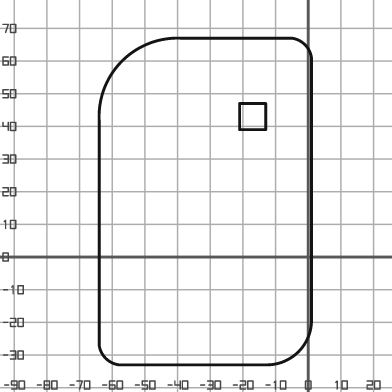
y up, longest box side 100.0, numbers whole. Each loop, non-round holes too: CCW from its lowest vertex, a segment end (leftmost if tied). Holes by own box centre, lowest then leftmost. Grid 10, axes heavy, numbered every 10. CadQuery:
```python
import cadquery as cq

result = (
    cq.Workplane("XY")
    .moveTo(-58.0, -33.0)
    .lineTo(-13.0, -33.0)
    .threePointArc((-3.0, -29.0), (1.0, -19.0))
    .lineTo(1.0, 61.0)
    .threePointArc((-1.0, 65.0), (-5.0, 67.0))
    .lineTo(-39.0, 67.0)
    .threePointArc((-57.0, 60.0), (-64.0, 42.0))
    .lineTo(-64.0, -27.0)
    .threePointArc((-62.0, -31.0), (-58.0, -33.0))
    .close()
    .moveTo(-21.0, 39.0)
    .lineTo(-13.0, 39.0)
    .lineTo(-13.0, 47.0)
    .lineTo(-21.0, 47.0)
    .close()
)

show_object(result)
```